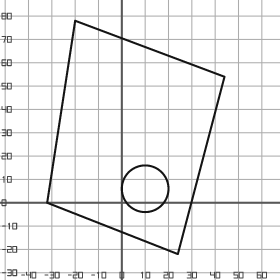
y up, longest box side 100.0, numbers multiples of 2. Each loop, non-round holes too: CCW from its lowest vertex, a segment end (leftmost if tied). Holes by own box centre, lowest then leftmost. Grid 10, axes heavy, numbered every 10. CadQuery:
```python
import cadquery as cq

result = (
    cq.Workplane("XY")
    .moveTo(24.0, -22.0)
    .lineTo(44.0, 54.0)
    .lineTo(-20.0, 78.0)
    .lineTo(-32.0, 0.0)
    .close()
    .moveTo(10.0, 6.0)
    .circle(10.0)
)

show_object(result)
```